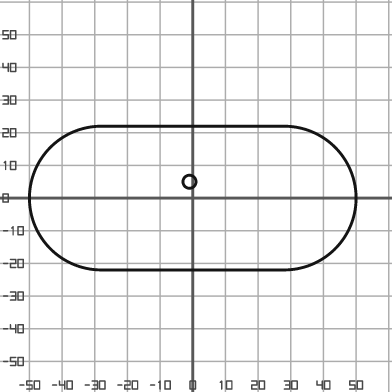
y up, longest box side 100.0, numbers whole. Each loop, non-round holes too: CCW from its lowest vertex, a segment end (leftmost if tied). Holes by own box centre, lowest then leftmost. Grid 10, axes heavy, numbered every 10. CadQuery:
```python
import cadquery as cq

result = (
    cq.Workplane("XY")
    .moveTo(-28.0, -22.0)
    .lineTo(28.0, -22.0)
    .threePointArc((50.0, 0.0), (28.0, 22.0))
    .lineTo(-28.0, 22.0)
    .threePointArc((-50.0, 0.0), (-28.0, -22.0))
    .close()
    .moveTo(-1.0, 5.0)
    .circle(2.0)
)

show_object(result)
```